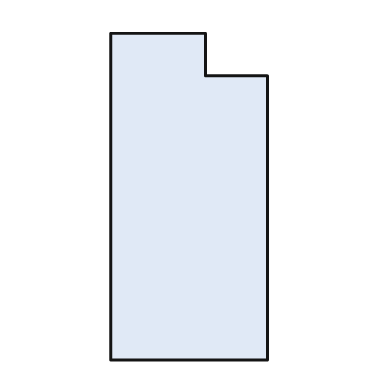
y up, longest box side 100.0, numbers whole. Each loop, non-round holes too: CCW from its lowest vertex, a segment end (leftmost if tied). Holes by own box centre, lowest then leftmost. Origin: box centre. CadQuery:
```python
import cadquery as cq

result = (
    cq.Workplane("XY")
    .moveTo(-24.0, -50.0)
    .lineTo(24.0, -50.0)
    .lineTo(24.0, 37.0)
    .lineTo(5.0, 37.0)
    .lineTo(5.0, 50.0)
    .lineTo(-24.0, 50.0)
    .close()
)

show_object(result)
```